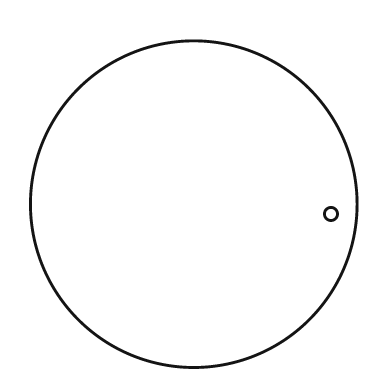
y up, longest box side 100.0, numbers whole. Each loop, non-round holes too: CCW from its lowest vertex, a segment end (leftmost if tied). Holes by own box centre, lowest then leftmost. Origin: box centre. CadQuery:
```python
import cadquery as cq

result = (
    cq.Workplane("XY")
    .moveTo(0.0, 0.0)
    .circle(50.0)
    .moveTo(42.0, -3.0)
    .circle(2.0)
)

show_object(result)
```